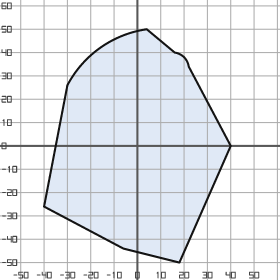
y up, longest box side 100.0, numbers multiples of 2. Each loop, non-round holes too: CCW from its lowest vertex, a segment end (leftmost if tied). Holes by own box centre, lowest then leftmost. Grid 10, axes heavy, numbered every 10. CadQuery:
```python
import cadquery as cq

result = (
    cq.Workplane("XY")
    .moveTo(18.0, -50.0)
    .lineTo(40.0, 0.0)
    .lineTo(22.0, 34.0)
    .threePointArc((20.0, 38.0), (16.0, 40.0))
    .lineTo(4.0, 50.0)
    .threePointArc((-16.0, 42.0), (-30.0, 26.0))
    .lineTo(-40.0, -26.0)
    .lineTo(-6.0, -44.0)
    .close()
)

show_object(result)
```